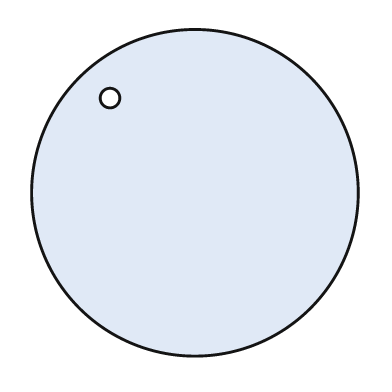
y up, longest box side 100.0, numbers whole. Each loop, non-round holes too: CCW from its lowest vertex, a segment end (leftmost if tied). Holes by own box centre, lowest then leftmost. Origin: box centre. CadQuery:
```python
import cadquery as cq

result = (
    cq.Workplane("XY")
    .moveTo(0.0, 0.0)
    .circle(50.0)
    .moveTo(-26.0, 29.0)
    .circle(3.0)
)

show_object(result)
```